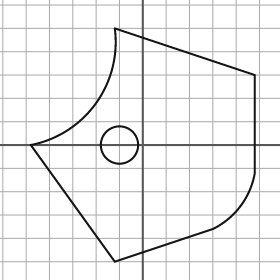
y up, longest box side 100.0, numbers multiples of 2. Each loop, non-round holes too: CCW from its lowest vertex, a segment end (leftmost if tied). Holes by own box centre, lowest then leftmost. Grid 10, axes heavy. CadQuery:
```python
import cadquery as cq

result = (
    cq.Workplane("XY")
    .moveTo(-12.0, -50.0)
    .lineTo(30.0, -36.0)
    .threePointArc((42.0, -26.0), (48.0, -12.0))
    .lineTo(48.0, 30.0)
    .lineTo(-12.0, 50.0)
    .threePointArc((-20.0, 18.0), (-48.0, 0.0))
    .close()
    .moveTo(-10.0, 0.0)
    .circle(8.0)
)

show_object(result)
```